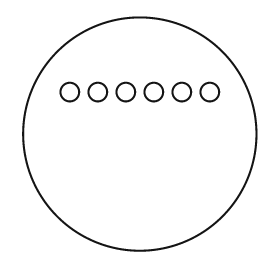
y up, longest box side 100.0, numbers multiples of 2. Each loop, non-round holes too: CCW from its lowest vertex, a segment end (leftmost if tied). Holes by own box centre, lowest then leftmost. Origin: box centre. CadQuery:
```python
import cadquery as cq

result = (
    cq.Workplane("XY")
    .moveTo(0.0, 0.0)
    .circle(50.0)
    .moveTo(-30.0, 18.0)
    .circle(4.0)
    .moveTo(-18.0, 18.0)
    .circle(4.0)
    .moveTo(-6.0, 18.0)
    .circle(4.0)
    .moveTo(6.0, 18.0)
    .circle(4.0)
    .moveTo(18.0, 18.0)
    .circle(4.0)
    .moveTo(30.0, 18.0)
    .circle(4.0)
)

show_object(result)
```